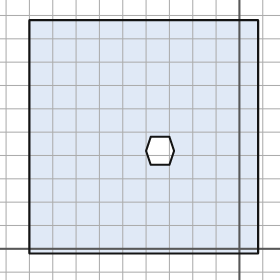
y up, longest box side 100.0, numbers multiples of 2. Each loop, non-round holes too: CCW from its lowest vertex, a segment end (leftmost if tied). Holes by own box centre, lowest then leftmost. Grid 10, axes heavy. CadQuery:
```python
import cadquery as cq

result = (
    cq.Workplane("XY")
    .moveTo(-90.0, -2.0)
    .lineTo(8.0, -2.0)
    .lineTo(8.0, 98.0)
    .lineTo(-90.0, 98.0)
    .close()
    .moveTo(-38.0, 36.0)
    .lineTo(-30.0, 36.0)
    .lineTo(-28.0, 42.0)
    .lineTo(-30.0, 48.0)
    .lineTo(-38.0, 48.0)
    .lineTo(-40.0, 42.0)
    .close()
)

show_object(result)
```